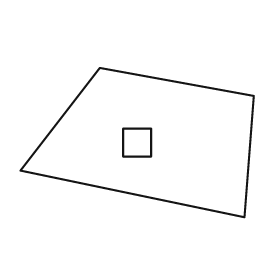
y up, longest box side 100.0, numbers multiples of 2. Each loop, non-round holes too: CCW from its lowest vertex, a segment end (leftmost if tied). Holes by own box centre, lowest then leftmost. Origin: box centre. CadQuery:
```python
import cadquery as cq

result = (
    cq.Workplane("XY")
    .moveTo(46.0, -32.0)
    .lineTo(50.0, 20.0)
    .lineTo(-16.0, 32.0)
    .lineTo(-50.0, -12.0)
    .close()
    .moveTo(-6.0, -6.0)
    .lineTo(6.0, -6.0)
    .lineTo(6.0, 6.0)
    .lineTo(-6.0, 6.0)
    .close()
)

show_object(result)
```